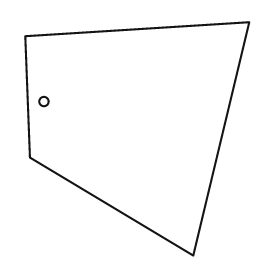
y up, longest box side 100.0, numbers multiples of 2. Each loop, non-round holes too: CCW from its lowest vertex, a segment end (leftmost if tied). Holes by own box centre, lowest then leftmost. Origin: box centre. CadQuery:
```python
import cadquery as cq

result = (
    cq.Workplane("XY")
    .moveTo(24.0, -50.0)
    .lineTo(48.0, 50.0)
    .lineTo(-48.0, 44.0)
    .lineTo(-46.0, -8.0)
    .close()
    .moveTo(-40.0, 16.0)
    .circle(2.0)
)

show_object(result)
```